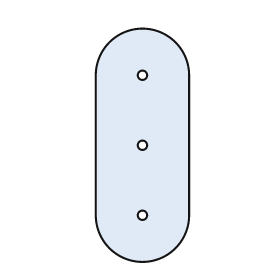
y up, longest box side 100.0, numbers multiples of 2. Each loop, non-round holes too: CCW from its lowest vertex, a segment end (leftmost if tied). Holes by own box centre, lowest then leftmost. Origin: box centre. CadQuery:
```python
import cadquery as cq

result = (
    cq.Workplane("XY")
    .moveTo(-20.0, -30.0)
    .threePointArc((0.0, -50.0), (20.0, -30.0))
    .lineTo(20.0, 30.0)
    .threePointArc((0.0, 50.0), (-20.0, 30.0))
    .close()
    .moveTo(0.0, -30.0)
    .circle(2.0)
    .moveTo(0.0, 0.0)
    .circle(2.0)
    .moveTo(0.0, 30.0)
    .circle(2.0)
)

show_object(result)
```